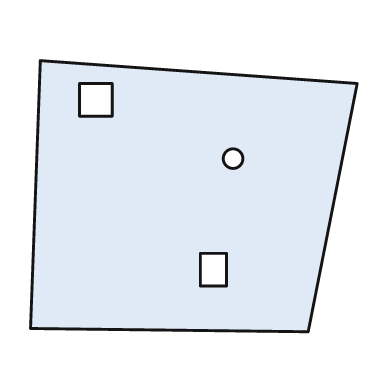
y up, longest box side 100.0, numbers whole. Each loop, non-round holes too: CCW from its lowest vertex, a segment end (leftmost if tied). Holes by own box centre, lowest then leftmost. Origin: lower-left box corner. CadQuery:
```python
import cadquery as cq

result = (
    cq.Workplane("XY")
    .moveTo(85.0, 0.0)
    .lineTo(100.0, 76.0)
    .lineTo(3.0, 83.0)
    .lineTo(0.0, 1.0)
    .close()
    .moveTo(52.0, 14.0)
    .lineTo(60.0, 14.0)
    .lineTo(60.0, 24.0)
    .lineTo(52.0, 24.0)
    .close()
    .moveTo(62.0, 53.0)
    .circle(3.0)
    .moveTo(15.0, 66.0)
    .lineTo(25.0, 66.0)
    .lineTo(25.0, 76.0)
    .lineTo(15.0, 76.0)
    .close()
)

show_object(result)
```